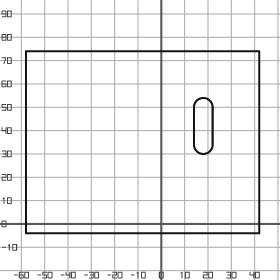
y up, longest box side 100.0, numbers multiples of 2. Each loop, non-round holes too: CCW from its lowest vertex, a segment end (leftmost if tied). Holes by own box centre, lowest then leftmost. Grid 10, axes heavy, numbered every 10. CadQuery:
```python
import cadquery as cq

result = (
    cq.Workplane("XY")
    .moveTo(-58.0, -4.0)
    .lineTo(42.0, -4.0)
    .lineTo(42.0, 74.0)
    .lineTo(-58.0, 74.0)
    .close()
    .moveTo(14.0, 34.0)
    .threePointArc((18.0, 30.0), (22.0, 34.0))
    .lineTo(22.0, 50.0)
    .threePointArc((18.0, 54.0), (14.0, 50.0))
    .close()
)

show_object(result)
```